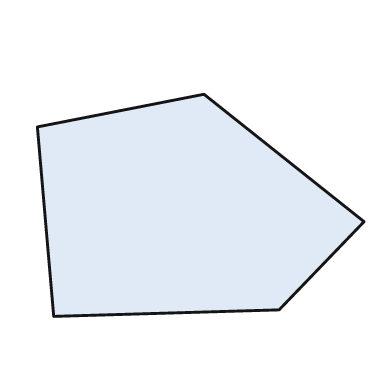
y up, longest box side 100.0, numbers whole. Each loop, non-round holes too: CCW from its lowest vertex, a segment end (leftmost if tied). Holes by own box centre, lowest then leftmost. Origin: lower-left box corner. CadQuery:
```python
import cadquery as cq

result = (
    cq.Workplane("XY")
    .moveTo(5.0, 0.0)
    .lineTo(74.0, 2.0)
    .lineTo(100.0, 29.0)
    .lineTo(51.0, 68.0)
    .lineTo(0.0, 58.0)
    .close()
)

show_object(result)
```